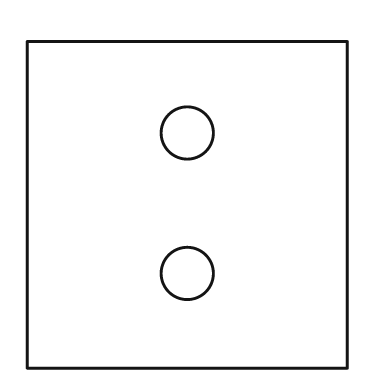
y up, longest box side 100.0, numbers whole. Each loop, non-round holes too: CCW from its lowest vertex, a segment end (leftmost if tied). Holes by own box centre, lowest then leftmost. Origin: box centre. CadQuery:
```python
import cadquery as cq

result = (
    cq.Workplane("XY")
    .moveTo(-49.0, -50.0)
    .lineTo(49.0, -50.0)
    .lineTo(49.0, 50.0)
    .lineTo(-49.0, 50.0)
    .close()
    .moveTo(0.0, -21.0)
    .circle(8.0)
    .moveTo(0.0, 22.0)
    .circle(8.0)
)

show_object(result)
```